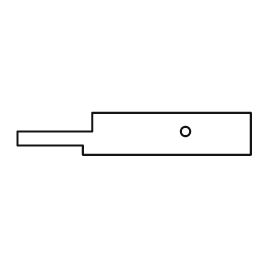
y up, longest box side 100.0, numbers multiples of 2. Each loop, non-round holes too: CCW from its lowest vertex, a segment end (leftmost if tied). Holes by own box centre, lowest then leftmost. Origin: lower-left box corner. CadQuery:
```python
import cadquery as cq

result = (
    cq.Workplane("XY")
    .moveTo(28.0, 0.0)
    .lineTo(100.0, 0.0)
    .lineTo(100.0, 18.0)
    .lineTo(32.0, 18.0)
    .lineTo(32.0, 10.0)
    .lineTo(0.0, 10.0)
    .lineTo(0.0, 4.0)
    .lineTo(28.0, 4.0)
    .close()
    .moveTo(72.0, 10.0)
    .circle(2.0)
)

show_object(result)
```